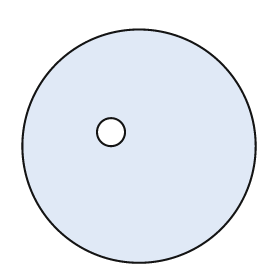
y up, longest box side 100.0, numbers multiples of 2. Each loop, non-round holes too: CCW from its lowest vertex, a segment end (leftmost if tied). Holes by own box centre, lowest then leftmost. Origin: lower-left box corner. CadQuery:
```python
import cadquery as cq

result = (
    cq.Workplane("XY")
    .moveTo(50.0, 50.0)
    .circle(50.0)
    .moveTo(38.0, 56.0)
    .circle(6.0)
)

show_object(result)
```